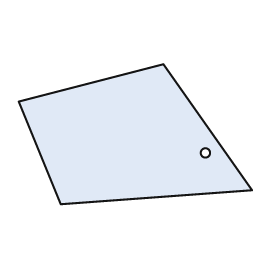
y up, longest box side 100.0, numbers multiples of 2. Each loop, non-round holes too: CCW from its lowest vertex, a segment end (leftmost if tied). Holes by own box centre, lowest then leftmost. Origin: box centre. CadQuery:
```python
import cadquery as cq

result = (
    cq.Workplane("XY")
    .moveTo(-32.0, -30.0)
    .lineTo(50.0, -24.0)
    .lineTo(12.0, 30.0)
    .lineTo(-50.0, 14.0)
    .close()
    .moveTo(30.0, -8.0)
    .circle(2.0)
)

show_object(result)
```